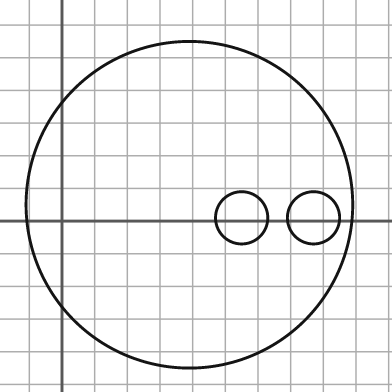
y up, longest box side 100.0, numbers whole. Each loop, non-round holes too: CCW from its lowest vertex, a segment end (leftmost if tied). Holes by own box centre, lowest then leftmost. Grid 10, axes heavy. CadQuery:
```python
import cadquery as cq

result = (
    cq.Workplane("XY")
    .moveTo(39.0, 5.0)
    .circle(50.0)
    .moveTo(55.0, 1.0)
    .circle(8.0)
    .moveTo(77.0, 1.0)
    .circle(8.0)
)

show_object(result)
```